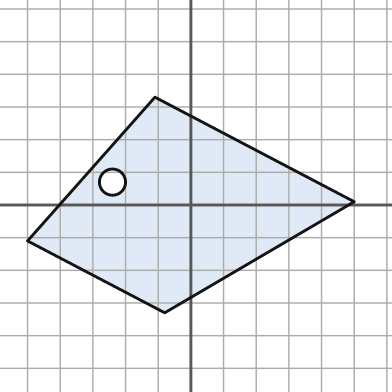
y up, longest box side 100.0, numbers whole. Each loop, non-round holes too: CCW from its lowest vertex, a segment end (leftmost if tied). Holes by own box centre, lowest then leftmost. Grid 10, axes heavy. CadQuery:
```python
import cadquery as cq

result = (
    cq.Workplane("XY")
    .moveTo(-8.0, -33.0)
    .lineTo(50.0, 1.0)
    .lineTo(-11.0, 33.0)
    .lineTo(-50.0, -11.0)
    .close()
    .moveTo(-24.0, 7.0)
    .circle(4.0)
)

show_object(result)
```